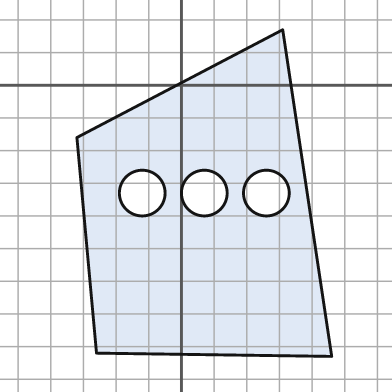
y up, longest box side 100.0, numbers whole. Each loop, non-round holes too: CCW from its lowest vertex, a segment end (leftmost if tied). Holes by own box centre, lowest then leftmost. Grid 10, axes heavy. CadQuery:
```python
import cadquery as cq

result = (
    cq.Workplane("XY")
    .moveTo(46.0, -83.0)
    .lineTo(31.0, 17.0)
    .lineTo(-32.0, -16.0)
    .lineTo(-26.0, -82.0)
    .close()
    .moveTo(-12.0, -33.0)
    .circle(7.0)
    .moveTo(7.0, -33.0)
    .circle(7.0)
    .moveTo(26.0, -33.0)
    .circle(7.0)
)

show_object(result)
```